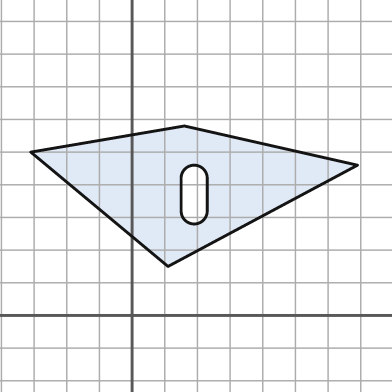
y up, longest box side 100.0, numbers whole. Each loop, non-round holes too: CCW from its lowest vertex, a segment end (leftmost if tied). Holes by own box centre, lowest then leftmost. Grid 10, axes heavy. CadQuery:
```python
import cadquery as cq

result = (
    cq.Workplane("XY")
    .moveTo(11.0, 15.0)
    .lineTo(69.0, 46.0)
    .lineTo(16.0, 58.0)
    .lineTo(-31.0, 50.0)
    .close()
    .moveTo(15.0, 32.0)
    .threePointArc((19.0, 28.0), (23.0, 32.0))
    .lineTo(23.0, 42.0)
    .threePointArc((19.0, 46.0), (15.0, 42.0))
    .close()
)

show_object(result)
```